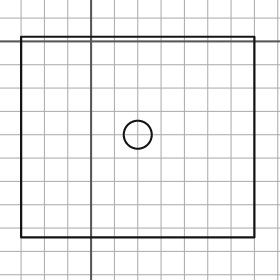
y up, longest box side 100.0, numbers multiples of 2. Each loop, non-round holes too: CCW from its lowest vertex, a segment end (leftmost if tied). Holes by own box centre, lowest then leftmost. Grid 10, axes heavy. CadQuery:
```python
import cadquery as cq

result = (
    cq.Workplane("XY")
    .moveTo(-30.0, -84.0)
    .lineTo(70.0, -84.0)
    .lineTo(70.0, 2.0)
    .lineTo(-30.0, 2.0)
    .close()
    .moveTo(20.0, -40.0)
    .circle(6.0)
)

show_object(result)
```